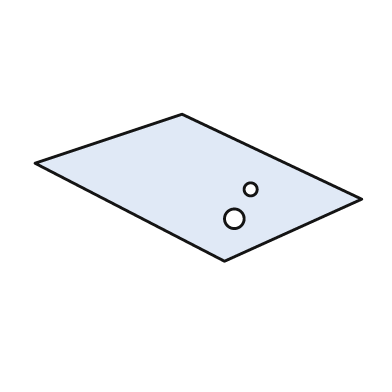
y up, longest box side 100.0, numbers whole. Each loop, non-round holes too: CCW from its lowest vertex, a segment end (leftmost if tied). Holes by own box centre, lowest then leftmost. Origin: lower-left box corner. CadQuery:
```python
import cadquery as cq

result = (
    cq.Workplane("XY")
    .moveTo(58.0, 0.0)
    .lineTo(100.0, 19.0)
    .lineTo(45.0, 45.0)
    .lineTo(0.0, 30.0)
    .close()
    .moveTo(61.0, 13.0)
    .circle(3.0)
    .moveTo(66.0, 22.0)
    .circle(2.0)
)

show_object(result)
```